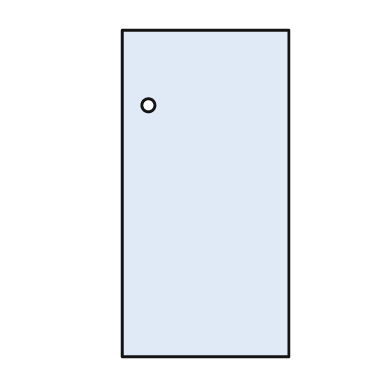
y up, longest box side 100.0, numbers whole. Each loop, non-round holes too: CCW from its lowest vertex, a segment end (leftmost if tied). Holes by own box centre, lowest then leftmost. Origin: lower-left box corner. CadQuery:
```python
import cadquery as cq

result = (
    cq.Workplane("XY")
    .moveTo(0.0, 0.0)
    .lineTo(51.0, 0.0)
    .lineTo(51.0, 100.0)
    .lineTo(0.0, 100.0)
    .close()
    .moveTo(8.0, 77.0)
    .circle(2.0)
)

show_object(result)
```